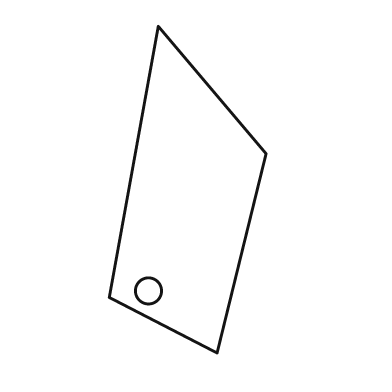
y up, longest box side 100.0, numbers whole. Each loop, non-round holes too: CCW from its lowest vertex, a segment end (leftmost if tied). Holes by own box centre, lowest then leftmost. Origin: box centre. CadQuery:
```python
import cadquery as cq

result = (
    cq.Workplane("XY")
    .moveTo(9.0, -50.0)
    .lineTo(24.0, 11.0)
    .lineTo(-9.0, 50.0)
    .lineTo(-24.0, -33.0)
    .close()
    .moveTo(-12.0, -31.0)
    .circle(4.0)
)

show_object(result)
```